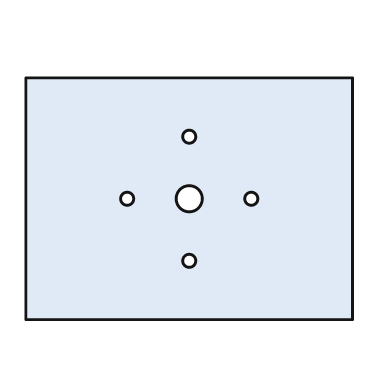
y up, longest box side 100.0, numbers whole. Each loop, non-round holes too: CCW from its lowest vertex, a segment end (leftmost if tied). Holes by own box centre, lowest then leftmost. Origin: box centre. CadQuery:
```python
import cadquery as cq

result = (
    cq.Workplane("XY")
    .moveTo(-50.0, -37.0)
    .lineTo(50.0, -37.0)
    .lineTo(50.0, 37.0)
    .lineTo(-50.0, 37.0)
    .close()
    .moveTo(0.0, -19.0)
    .circle(2.0)
    .moveTo(-19.0, 0.0)
    .circle(2.0)
    .moveTo(0.0, 0.0)
    .circle(4.0)
    .moveTo(19.0, 0.0)
    .circle(2.0)
    .moveTo(0.0, 19.0)
    .circle(2.0)
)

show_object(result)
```